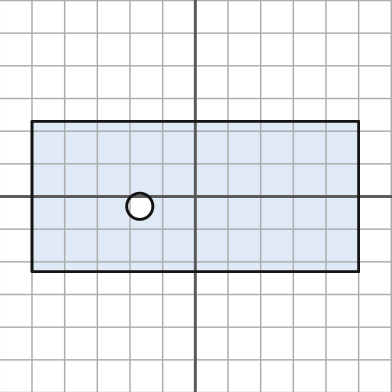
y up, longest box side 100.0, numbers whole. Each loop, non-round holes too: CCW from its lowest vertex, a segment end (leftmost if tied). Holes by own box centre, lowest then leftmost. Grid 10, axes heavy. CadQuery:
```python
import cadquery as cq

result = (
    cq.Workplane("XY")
    .moveTo(-50.0, -23.0)
    .lineTo(50.0, -23.0)
    .lineTo(50.0, 23.0)
    .lineTo(-50.0, 23.0)
    .close()
    .moveTo(-17.0, -3.0)
    .circle(4.0)
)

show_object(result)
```